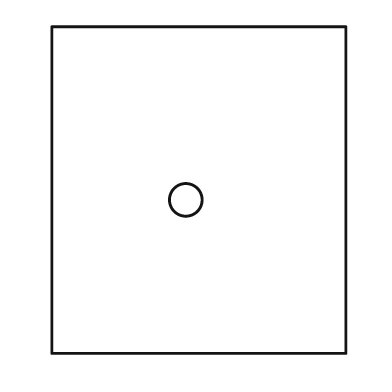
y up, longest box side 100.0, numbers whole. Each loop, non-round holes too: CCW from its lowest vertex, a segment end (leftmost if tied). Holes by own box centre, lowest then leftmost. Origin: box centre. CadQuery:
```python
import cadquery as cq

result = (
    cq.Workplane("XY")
    .moveTo(-45.0, -50.0)
    .lineTo(45.0, -50.0)
    .lineTo(45.0, 50.0)
    .lineTo(-45.0, 50.0)
    .close()
    .moveTo(-4.0, -3.0)
    .circle(5.0)
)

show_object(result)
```